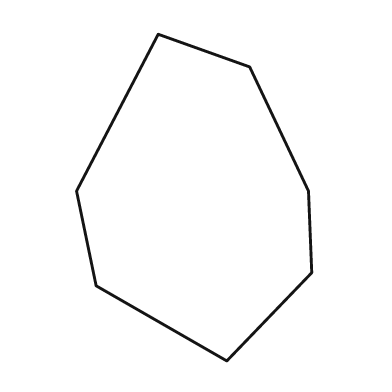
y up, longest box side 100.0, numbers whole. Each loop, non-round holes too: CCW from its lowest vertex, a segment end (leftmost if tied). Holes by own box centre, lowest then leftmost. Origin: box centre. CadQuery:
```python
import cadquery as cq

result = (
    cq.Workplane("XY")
    .moveTo(10.0, -50.0)
    .lineTo(36.0, -23.0)
    .lineTo(35.0, 2.0)
    .lineTo(17.0, 40.0)
    .lineTo(-11.0, 50.0)
    .lineTo(-36.0, 2.0)
    .lineTo(-30.0, -27.0)
    .close()
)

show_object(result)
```